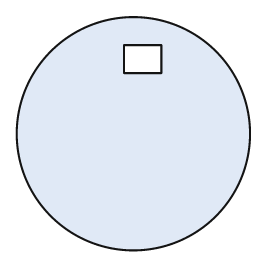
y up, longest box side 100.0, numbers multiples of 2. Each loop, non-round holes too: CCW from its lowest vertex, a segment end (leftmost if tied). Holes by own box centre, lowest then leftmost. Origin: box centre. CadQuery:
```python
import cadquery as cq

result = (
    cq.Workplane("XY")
    .moveTo(0.0, 0.0)
    .circle(50.0)
    .moveTo(-4.0, 26.0)
    .lineTo(12.0, 26.0)
    .lineTo(12.0, 38.0)
    .lineTo(-4.0, 38.0)
    .close()
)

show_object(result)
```